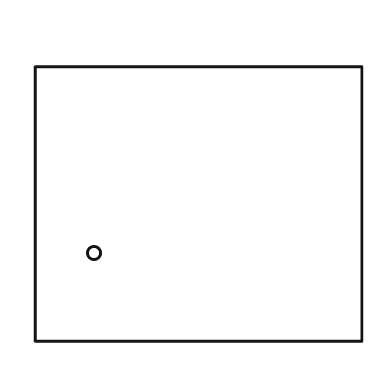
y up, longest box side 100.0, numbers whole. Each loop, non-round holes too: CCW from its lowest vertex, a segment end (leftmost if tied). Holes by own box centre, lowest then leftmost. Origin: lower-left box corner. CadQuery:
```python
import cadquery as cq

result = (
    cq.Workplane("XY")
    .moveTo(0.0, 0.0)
    .lineTo(100.0, 0.0)
    .lineTo(100.0, 84.0)
    .lineTo(0.0, 84.0)
    .close()
    .moveTo(18.0, 27.0)
    .circle(2.0)
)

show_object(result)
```